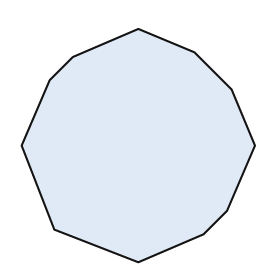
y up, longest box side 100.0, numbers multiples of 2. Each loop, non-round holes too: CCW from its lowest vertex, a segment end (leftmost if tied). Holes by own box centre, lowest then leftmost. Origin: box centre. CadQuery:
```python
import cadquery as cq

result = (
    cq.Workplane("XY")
    .moveTo(0.0, -50.0)
    .lineTo(28.0, -38.0)
    .lineTo(38.0, -28.0)
    .lineTo(50.0, 0.0)
    .lineTo(40.0, 24.0)
    .lineTo(24.0, 40.0)
    .lineTo(0.0, 50.0)
    .lineTo(-28.0, 38.0)
    .lineTo(-38.0, 28.0)
    .lineTo(-50.0, 0.0)
    .lineTo(-36.0, -36.0)
    .close()
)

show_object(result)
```